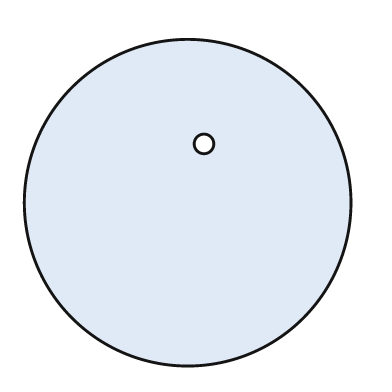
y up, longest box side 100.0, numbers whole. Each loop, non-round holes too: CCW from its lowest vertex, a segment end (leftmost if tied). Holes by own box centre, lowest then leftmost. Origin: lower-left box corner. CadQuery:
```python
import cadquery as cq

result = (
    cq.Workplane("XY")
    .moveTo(50.0, 50.0)
    .circle(50.0)
    .moveTo(55.0, 68.0)
    .circle(3.0)
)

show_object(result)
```